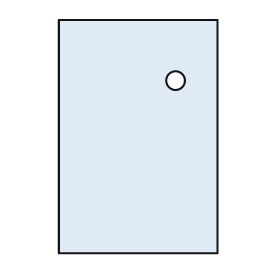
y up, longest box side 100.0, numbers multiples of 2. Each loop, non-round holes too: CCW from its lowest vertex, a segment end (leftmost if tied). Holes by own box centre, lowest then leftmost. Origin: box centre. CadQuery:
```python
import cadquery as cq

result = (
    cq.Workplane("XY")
    .moveTo(-34.0, -50.0)
    .lineTo(34.0, -50.0)
    .lineTo(34.0, 50.0)
    .lineTo(-34.0, 50.0)
    .close()
    .moveTo(16.0, 24.0)
    .circle(4.0)
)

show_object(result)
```